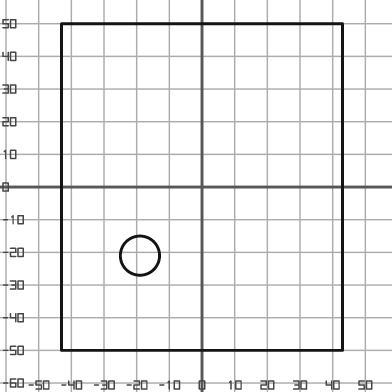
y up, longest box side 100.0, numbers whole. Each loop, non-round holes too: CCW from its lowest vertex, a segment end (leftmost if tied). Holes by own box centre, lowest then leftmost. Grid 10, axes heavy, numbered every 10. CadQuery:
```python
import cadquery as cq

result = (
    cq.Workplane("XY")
    .moveTo(-43.0, -50.0)
    .lineTo(43.0, -50.0)
    .lineTo(43.0, 50.0)
    .lineTo(-43.0, 50.0)
    .close()
    .moveTo(-19.0, -21.0)
    .circle(6.0)
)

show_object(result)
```